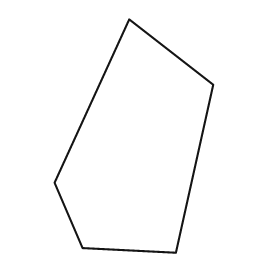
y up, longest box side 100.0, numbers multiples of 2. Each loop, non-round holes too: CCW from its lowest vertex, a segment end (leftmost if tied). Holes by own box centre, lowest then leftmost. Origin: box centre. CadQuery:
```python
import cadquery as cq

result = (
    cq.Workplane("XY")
    .moveTo(18.0, -50.0)
    .lineTo(34.0, 22.0)
    .lineTo(-2.0, 50.0)
    .lineTo(-34.0, -20.0)
    .lineTo(-22.0, -48.0)
    .close()
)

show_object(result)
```